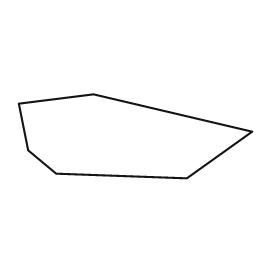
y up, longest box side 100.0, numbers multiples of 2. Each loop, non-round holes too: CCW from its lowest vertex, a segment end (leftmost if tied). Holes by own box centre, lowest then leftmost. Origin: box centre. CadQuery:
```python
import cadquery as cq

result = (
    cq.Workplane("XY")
    .moveTo(22.0, -18.0)
    .lineTo(50.0, 2.0)
    .lineTo(-18.0, 18.0)
    .lineTo(-50.0, 14.0)
    .lineTo(-46.0, -6.0)
    .lineTo(-34.0, -16.0)
    .close()
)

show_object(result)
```